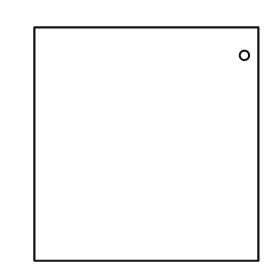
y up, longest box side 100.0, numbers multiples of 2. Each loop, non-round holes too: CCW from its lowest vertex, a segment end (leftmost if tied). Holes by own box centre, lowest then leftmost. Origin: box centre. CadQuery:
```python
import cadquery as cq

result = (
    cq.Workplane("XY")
    .moveTo(-48.0, -50.0)
    .lineTo(48.0, -50.0)
    .lineTo(48.0, 50.0)
    .lineTo(-48.0, 50.0)
    .close()
    .moveTo(42.0, 38.0)
    .circle(2.0)
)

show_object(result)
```